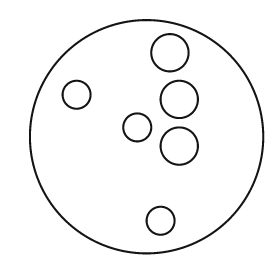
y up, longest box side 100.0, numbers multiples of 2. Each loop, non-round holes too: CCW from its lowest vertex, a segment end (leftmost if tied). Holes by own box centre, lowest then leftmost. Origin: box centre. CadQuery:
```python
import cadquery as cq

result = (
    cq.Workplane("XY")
    .moveTo(0.0, 0.0)
    .circle(50.0)
    .moveTo(6.0, -36.0)
    .circle(6.0)
    .moveTo(14.0, -4.0)
    .circle(8.0)
    .moveTo(-4.0, 4.0)
    .circle(6.0)
    .moveTo(14.0, 16.0)
    .circle(8.0)
    .moveTo(-30.0, 18.0)
    .circle(6.0)
    .moveTo(10.0, 36.0)
    .circle(8.0)
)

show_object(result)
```